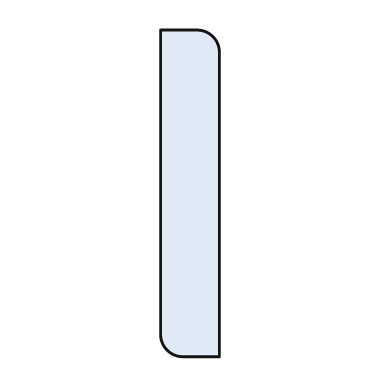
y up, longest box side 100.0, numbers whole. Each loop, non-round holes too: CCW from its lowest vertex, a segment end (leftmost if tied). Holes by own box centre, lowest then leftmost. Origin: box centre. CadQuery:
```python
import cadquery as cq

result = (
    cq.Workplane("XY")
    .moveTo(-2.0, -50.0)
    .lineTo(9.0, -50.0)
    .lineTo(9.0, 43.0)
    .threePointArc((7.0, 48.0), (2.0, 50.0))
    .lineTo(-9.0, 50.0)
    .lineTo(-9.0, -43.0)
    .threePointArc((-7.0, -48.0), (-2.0, -50.0))
    .close()
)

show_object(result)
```